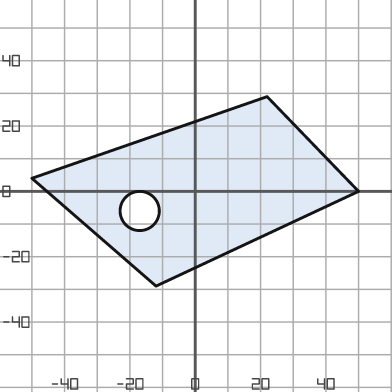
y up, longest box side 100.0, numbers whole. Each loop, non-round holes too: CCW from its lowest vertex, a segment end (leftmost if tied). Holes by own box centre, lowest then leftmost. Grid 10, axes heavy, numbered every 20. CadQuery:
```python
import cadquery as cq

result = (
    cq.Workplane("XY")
    .moveTo(-12.0, -29.0)
    .lineTo(50.0, 0.0)
    .lineTo(22.0, 29.0)
    .lineTo(-50.0, 4.0)
    .close()
    .moveTo(-17.0, -6.0)
    .circle(6.0)
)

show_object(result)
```